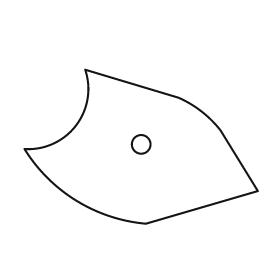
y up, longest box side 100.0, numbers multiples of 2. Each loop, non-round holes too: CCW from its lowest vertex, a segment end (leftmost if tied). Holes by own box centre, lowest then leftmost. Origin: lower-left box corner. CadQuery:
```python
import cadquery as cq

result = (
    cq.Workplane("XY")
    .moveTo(52.0, 0.0)
    .lineTo(100.0, 14.0)
    .lineTo(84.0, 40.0)
    .threePointArc((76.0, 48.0), (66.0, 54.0))
    .lineTo(26.0, 66.0)
    .threePointArc((22.0, 42.0), (0.0, 32.0))
    .threePointArc((22.0, 10.0), (52.0, 0.0))
    .close()
    .moveTo(50.0, 34.0)
    .circle(4.0)
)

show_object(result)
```